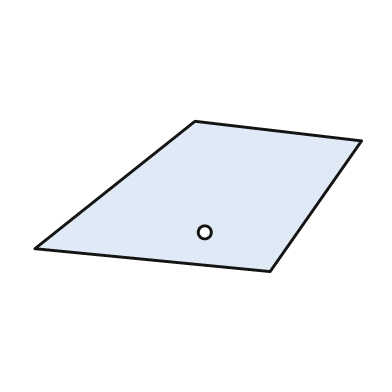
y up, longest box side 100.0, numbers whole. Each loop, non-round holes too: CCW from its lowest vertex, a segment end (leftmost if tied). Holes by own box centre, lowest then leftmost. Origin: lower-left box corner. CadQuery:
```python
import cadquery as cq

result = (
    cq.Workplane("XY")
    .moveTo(72.0, 0.0)
    .lineTo(100.0, 40.0)
    .lineTo(49.0, 46.0)
    .lineTo(0.0, 7.0)
    .close()
    .moveTo(52.0, 12.0)
    .circle(2.0)
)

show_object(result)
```